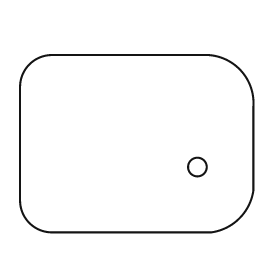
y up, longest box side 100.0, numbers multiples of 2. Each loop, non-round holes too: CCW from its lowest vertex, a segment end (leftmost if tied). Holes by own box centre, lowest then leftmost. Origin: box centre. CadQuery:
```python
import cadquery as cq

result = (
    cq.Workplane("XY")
    .moveTo(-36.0, -38.0)
    .lineTo(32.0, -38.0)
    .threePointArc((44.0, -32.0), (50.0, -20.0))
    .lineTo(50.0, 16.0)
    .threePointArc((44.0, 32.0), (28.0, 38.0))
    .lineTo(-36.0, 38.0)
    .threePointArc((-46.0, 34.0), (-50.0, 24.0))
    .lineTo(-50.0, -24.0)
    .threePointArc((-46.0, -34.0), (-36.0, -38.0))
    .close()
    .moveTo(26.0, -10.0)
    .circle(4.0)
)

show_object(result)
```